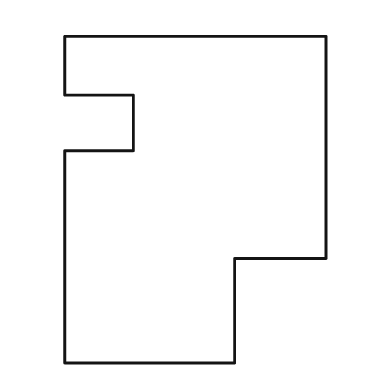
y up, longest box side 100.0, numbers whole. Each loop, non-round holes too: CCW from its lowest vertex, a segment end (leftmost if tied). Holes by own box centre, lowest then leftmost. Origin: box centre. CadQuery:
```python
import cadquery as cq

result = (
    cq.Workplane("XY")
    .moveTo(-40.0, -50.0)
    .lineTo(12.0, -50.0)
    .lineTo(12.0, -18.0)
    .lineTo(40.0, -18.0)
    .lineTo(40.0, 50.0)
    .lineTo(-40.0, 50.0)
    .lineTo(-40.0, 32.0)
    .lineTo(-19.0, 32.0)
    .lineTo(-19.0, 15.0)
    .lineTo(-40.0, 15.0)
    .close()
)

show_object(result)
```